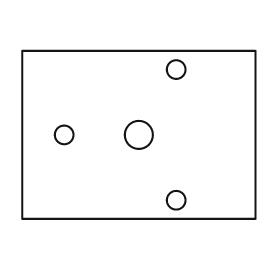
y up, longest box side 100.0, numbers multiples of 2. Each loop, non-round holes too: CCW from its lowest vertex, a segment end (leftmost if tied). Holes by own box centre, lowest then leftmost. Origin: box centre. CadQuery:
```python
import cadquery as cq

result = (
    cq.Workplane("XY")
    .moveTo(-50.0, -36.0)
    .lineTo(50.0, -36.0)
    .lineTo(50.0, 36.0)
    .lineTo(-50.0, 36.0)
    .close()
    .moveTo(16.0, -28.0)
    .circle(4.0)
    .moveTo(-32.0, 0.0)
    .circle(4.0)
    .moveTo(0.0, 0.0)
    .circle(6.0)
    .moveTo(16.0, 28.0)
    .circle(4.0)
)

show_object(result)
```